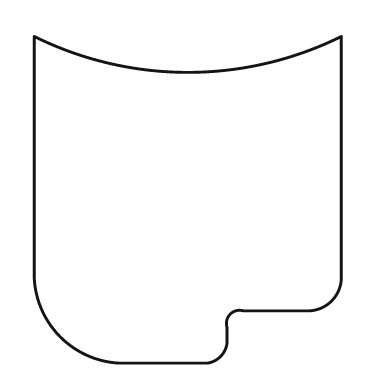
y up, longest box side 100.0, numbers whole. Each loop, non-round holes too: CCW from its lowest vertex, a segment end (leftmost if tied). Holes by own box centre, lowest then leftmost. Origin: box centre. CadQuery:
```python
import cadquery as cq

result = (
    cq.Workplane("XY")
    .moveTo(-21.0, -50.0)
    .lineTo(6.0, -50.0)
    .threePointArc((10.0, -48.0), (12.0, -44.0))
    .lineTo(12.0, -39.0)
    .threePointArc((13.0, -35.0), (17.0, -34.0))
    .lineTo(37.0, -34.0)
    .threePointArc((44.0, -31.0), (47.0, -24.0))
    .lineTo(47.0, 50.0)
    .threePointArc((0.0, 39.0), (-47.0, 50.0))
    .lineTo(-47.0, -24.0)
    .threePointArc((-39.0, -42.0), (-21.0, -50.0))
    .close()
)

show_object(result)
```